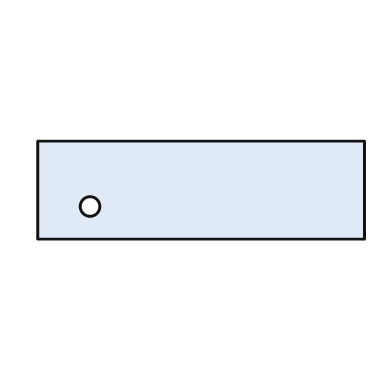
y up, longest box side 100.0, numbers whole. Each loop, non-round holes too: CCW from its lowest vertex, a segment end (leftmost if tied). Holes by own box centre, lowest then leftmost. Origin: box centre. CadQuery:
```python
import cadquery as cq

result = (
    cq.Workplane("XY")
    .moveTo(-50.0, -15.0)
    .lineTo(50.0, -15.0)
    .lineTo(50.0, 15.0)
    .lineTo(-50.0, 15.0)
    .close()
    .moveTo(-34.0, -5.0)
    .circle(3.0)
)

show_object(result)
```